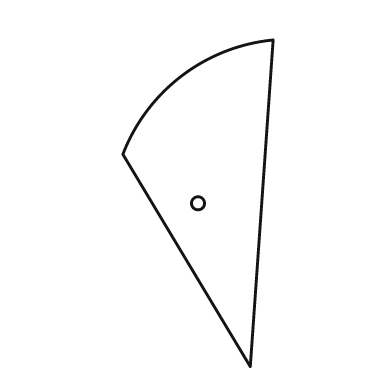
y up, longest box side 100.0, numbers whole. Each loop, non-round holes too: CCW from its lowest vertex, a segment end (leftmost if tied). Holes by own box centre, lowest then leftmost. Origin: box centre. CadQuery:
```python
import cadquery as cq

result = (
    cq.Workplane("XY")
    .moveTo(16.0, -50.0)
    .lineTo(23.0, 50.0)
    .threePointArc((-5.0, 39.0), (-23.0, 15.0))
    .close()
    .moveTo(0.0, 0.0)
    .circle(2.0)
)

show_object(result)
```